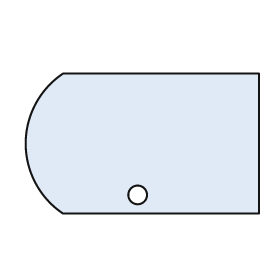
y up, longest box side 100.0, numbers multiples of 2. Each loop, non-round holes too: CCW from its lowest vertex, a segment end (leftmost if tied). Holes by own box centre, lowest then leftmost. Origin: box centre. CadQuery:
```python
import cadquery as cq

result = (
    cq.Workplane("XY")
    .moveTo(-34.0, -30.0)
    .lineTo(50.0, -30.0)
    .lineTo(50.0, 30.0)
    .lineTo(-34.0, 30.0)
    .threePointArc((-50.0, 0.0), (-34.0, -30.0))
    .close()
    .moveTo(-2.0, -22.0)
    .circle(4.0)
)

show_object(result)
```